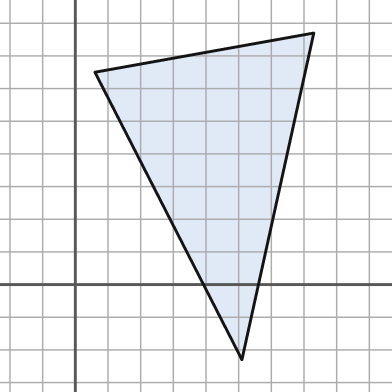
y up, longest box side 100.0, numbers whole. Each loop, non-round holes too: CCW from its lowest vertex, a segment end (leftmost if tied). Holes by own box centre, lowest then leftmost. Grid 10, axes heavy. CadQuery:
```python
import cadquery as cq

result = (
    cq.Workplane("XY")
    .moveTo(51.0, -23.0)
    .lineTo(73.0, 77.0)
    .lineTo(6.0, 65.0)
    .close()
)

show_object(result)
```